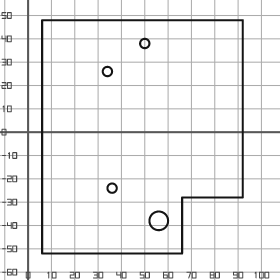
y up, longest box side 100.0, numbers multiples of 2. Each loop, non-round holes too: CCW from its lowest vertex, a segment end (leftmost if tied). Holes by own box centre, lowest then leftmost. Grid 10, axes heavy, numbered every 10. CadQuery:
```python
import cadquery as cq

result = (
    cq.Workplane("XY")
    .moveTo(6.0, -52.0)
    .lineTo(66.0, -52.0)
    .lineTo(66.0, -28.0)
    .lineTo(92.0, -28.0)
    .lineTo(92.0, 48.0)
    .lineTo(6.0, 48.0)
    .close()
    .moveTo(56.0, -38.0)
    .circle(4.0)
    .moveTo(36.0, -24.0)
    .circle(2.0)
    .moveTo(34.0, 26.0)
    .circle(2.0)
    .moveTo(50.0, 38.0)
    .circle(2.0)
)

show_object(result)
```